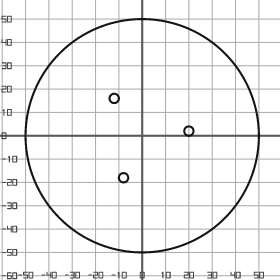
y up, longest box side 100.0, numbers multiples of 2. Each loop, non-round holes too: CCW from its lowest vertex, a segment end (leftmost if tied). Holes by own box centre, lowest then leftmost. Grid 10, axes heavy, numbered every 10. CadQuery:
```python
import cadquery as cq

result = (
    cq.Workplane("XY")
    .moveTo(0.0, 0.0)
    .circle(50.0)
    .moveTo(-8.0, -18.0)
    .circle(2.0)
    .moveTo(20.0, 2.0)
    .circle(2.0)
    .moveTo(-12.0, 16.0)
    .circle(2.0)
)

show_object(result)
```